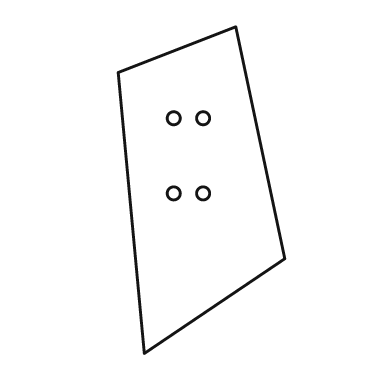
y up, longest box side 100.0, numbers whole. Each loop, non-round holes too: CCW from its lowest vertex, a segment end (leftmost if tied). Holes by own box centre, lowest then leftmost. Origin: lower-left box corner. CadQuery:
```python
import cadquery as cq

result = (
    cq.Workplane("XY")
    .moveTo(8.0, 0.0)
    .lineTo(51.0, 29.0)
    .lineTo(36.0, 100.0)
    .lineTo(0.0, 86.0)
    .close()
    .moveTo(17.0, 49.0)
    .circle(2.0)
    .moveTo(26.0, 49.0)
    .circle(2.0)
    .moveTo(17.0, 72.0)
    .circle(2.0)
    .moveTo(26.0, 72.0)
    .circle(2.0)
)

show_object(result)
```